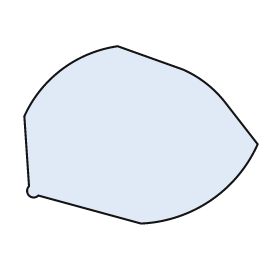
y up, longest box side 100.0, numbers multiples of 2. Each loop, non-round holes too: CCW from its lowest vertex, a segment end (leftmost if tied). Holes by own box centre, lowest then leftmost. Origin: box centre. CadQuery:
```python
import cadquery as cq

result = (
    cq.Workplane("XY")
    .moveTo(0.0, -38.0)
    .threePointArc((30.0, -28.0), (50.0, -4.0))
    .lineTo(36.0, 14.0)
    .threePointArc((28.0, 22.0), (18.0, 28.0))
    .lineTo(-10.0, 38.0)
    .threePointArc((-34.0, 28.0), (-50.0, 8.0))
    .lineTo(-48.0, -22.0)
    .threePointArc((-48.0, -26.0), (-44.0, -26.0))
    .close()
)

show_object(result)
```